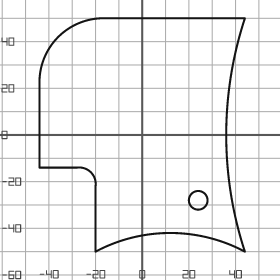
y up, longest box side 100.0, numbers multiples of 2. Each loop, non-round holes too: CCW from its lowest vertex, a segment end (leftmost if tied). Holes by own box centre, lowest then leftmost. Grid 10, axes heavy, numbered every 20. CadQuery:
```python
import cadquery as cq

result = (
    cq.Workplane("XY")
    .moveTo(-20.0, -50.0)
    .threePointArc((12.0, -42.0), (44.0, -50.0))
    .threePointArc((36.0, 0.0), (44.0, 50.0))
    .lineTo(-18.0, 50.0)
    .threePointArc((-36.0, 42.0), (-44.0, 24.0))
    .lineTo(-44.0, -14.0)
    .lineTo(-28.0, -14.0)
    .threePointArc((-22.0, -16.0), (-20.0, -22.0))
    .close()
    .moveTo(24.0, -28.0)
    .circle(4.0)
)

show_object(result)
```